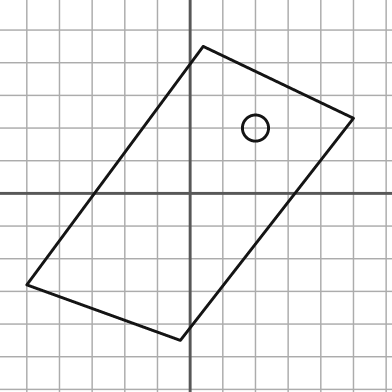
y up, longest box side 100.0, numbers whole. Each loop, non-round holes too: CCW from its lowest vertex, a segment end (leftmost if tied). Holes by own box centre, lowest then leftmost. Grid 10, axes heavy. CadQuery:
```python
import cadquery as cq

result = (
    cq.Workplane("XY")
    .moveTo(-3.0, -45.0)
    .lineTo(50.0, 23.0)
    .lineTo(4.0, 45.0)
    .lineTo(-50.0, -28.0)
    .close()
    .moveTo(20.0, 20.0)
    .circle(4.0)
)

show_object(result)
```